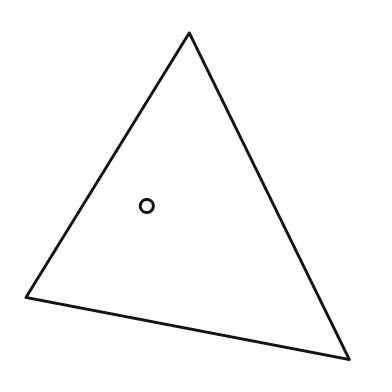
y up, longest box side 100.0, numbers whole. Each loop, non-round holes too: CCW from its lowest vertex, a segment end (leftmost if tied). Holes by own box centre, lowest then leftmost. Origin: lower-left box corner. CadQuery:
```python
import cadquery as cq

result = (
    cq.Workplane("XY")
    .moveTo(99.0, 0.0)
    .lineTo(50.0, 100.0)
    .lineTo(0.0, 19.0)
    .close()
    .moveTo(37.0, 47.0)
    .circle(2.0)
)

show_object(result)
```